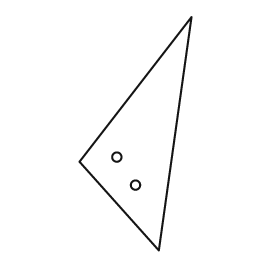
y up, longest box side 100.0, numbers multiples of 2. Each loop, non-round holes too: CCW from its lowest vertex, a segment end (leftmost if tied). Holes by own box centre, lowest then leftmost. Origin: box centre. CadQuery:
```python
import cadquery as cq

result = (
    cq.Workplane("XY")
    .moveTo(10.0, -50.0)
    .lineTo(24.0, 50.0)
    .lineTo(-24.0, -12.0)
    .close()
    .moveTo(0.0, -22.0)
    .circle(2.0)
    .moveTo(-8.0, -10.0)
    .circle(2.0)
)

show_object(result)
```